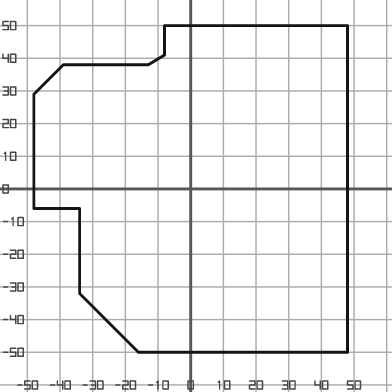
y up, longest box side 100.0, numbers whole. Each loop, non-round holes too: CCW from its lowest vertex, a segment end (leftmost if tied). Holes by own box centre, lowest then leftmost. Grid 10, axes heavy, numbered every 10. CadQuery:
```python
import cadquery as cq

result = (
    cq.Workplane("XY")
    .moveTo(-16.0, -50.0)
    .lineTo(48.0, -50.0)
    .lineTo(48.0, 50.0)
    .lineTo(-8.0, 50.0)
    .lineTo(-8.0, 41.0)
    .lineTo(-13.0, 38.0)
    .lineTo(-39.0, 38.0)
    .lineTo(-48.0, 29.0)
    .lineTo(-48.0, -6.0)
    .lineTo(-34.0, -6.0)
    .lineTo(-34.0, -32.0)
    .close()
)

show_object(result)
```